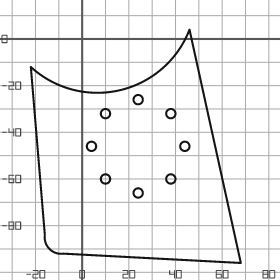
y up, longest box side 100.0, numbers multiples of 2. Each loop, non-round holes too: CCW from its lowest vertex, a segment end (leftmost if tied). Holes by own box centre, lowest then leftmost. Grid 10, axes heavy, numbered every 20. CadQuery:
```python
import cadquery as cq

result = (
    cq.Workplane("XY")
    .moveTo(68.0, -96.0)
    .lineTo(46.0, 4.0)
    .threePointArc((16.0, -22.0), (-22.0, -12.0))
    .lineTo(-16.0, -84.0)
    .threePointArc((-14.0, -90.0), (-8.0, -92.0))
    .close()
    .moveTo(24.0, -66.0)
    .circle(2.0)
    .moveTo(10.0, -60.0)
    .circle(2.0)
    .moveTo(38.0, -60.0)
    .circle(2.0)
    .moveTo(4.0, -46.0)
    .circle(2.0)
    .moveTo(44.0, -46.0)
    .circle(2.0)
    .moveTo(10.0, -32.0)
    .circle(2.0)
    .moveTo(38.0, -32.0)
    .circle(2.0)
    .moveTo(24.0, -26.0)
    .circle(2.0)
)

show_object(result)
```